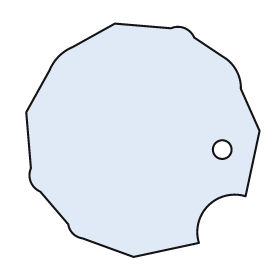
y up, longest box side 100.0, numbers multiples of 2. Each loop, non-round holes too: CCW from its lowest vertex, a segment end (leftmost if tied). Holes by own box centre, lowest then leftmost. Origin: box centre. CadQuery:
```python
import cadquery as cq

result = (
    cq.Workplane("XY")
    .moveTo(-4.0, -50.0)
    .lineTo(24.0, -44.0)
    .threePointArc((28.0, -28.0), (44.0, -24.0))
    .lineTo(50.0, 4.0)
    .lineTo(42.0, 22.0)
    .threePointArc((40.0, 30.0), (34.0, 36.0))
    .lineTo(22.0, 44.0)
    .threePointArc((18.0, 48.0), (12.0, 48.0))
    .lineTo(-12.0, 50.0)
    .lineTo(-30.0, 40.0)
    .threePointArc((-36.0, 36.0), (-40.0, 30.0))
    .lineTo(-50.0, 12.0)
    .lineTo(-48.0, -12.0)
    .threePointArc((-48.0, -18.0), (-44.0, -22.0))
    .lineTo(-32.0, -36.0)
    .threePointArc((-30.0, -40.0), (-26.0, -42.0))
    .close()
    .moveTo(34.0, -4.0)
    .circle(4.0)
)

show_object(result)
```